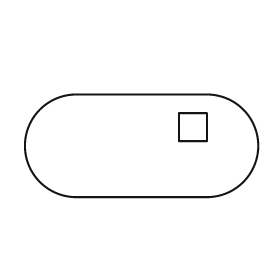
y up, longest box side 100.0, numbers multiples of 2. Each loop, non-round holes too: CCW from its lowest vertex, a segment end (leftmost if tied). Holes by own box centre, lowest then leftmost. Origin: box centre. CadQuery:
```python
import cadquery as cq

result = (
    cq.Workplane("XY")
    .moveTo(-28.0, -22.0)
    .lineTo(28.0, -22.0)
    .threePointArc((50.0, 0.0), (28.0, 22.0))
    .lineTo(-28.0, 22.0)
    .threePointArc((-50.0, 0.0), (-28.0, -22.0))
    .close()
    .moveTo(16.0, 2.0)
    .lineTo(28.0, 2.0)
    .lineTo(28.0, 14.0)
    .lineTo(16.0, 14.0)
    .close()
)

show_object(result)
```